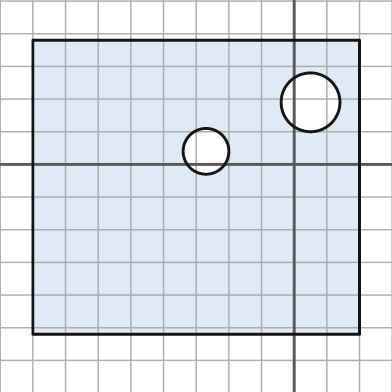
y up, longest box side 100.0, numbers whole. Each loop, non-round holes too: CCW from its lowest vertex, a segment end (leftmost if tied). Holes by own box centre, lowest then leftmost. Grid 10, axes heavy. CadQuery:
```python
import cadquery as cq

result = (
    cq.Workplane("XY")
    .moveTo(-80.0, -52.0)
    .lineTo(20.0, -52.0)
    .lineTo(20.0, 38.0)
    .lineTo(-80.0, 38.0)
    .close()
    .moveTo(-27.0, 4.0)
    .circle(7.0)
    .moveTo(5.0, 19.0)
    .circle(9.0)
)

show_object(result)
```